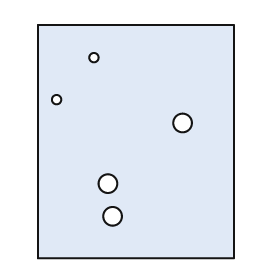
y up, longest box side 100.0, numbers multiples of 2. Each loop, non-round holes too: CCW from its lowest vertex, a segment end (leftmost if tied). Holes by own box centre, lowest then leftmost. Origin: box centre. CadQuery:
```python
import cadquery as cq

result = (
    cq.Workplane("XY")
    .moveTo(-42.0, -50.0)
    .lineTo(42.0, -50.0)
    .lineTo(42.0, 50.0)
    .lineTo(-42.0, 50.0)
    .close()
    .moveTo(-10.0, -32.0)
    .circle(4.0)
    .moveTo(-12.0, -18.0)
    .circle(4.0)
    .moveTo(20.0, 8.0)
    .circle(4.0)
    .moveTo(-34.0, 18.0)
    .circle(2.0)
    .moveTo(-18.0, 36.0)
    .circle(2.0)
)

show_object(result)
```